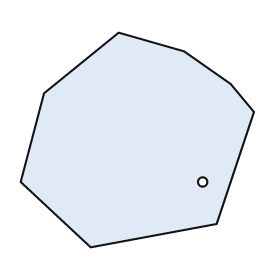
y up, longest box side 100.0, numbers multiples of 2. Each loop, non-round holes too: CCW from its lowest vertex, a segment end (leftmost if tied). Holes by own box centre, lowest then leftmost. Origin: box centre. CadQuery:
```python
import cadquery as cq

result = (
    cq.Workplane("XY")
    .moveTo(-20.0, -46.0)
    .lineTo(34.0, -36.0)
    .lineTo(50.0, 12.0)
    .lineTo(40.0, 24.0)
    .lineTo(20.0, 38.0)
    .lineTo(-8.0, 46.0)
    .lineTo(-40.0, 20.0)
    .lineTo(-50.0, -18.0)
    .close()
    .moveTo(28.0, -18.0)
    .circle(2.0)
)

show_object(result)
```